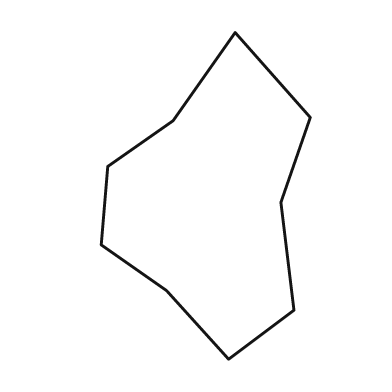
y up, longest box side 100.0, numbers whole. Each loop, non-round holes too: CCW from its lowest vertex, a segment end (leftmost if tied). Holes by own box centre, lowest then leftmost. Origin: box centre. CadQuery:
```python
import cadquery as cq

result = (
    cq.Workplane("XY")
    .moveTo(7.0, -50.0)
    .lineTo(27.0, -35.0)
    .lineTo(23.0, -2.0)
    .lineTo(32.0, 24.0)
    .lineTo(9.0, 50.0)
    .lineTo(-10.0, 23.0)
    .lineTo(-30.0, 9.0)
    .lineTo(-32.0, -15.0)
    .lineTo(-12.0, -29.0)
    .close()
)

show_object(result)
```